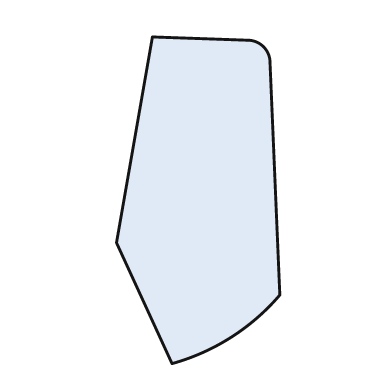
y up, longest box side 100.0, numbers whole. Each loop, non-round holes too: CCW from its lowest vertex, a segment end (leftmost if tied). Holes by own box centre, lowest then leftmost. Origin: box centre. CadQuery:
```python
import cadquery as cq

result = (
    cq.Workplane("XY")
    .moveTo(-8.0, -50.0)
    .threePointArc((10.0, -42.0), (25.0, -29.0))
    .lineTo(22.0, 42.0)
    .threePointArc((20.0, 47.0), (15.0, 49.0))
    .lineTo(-14.0, 50.0)
    .lineTo(-25.0, -13.0)
    .close()
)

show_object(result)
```